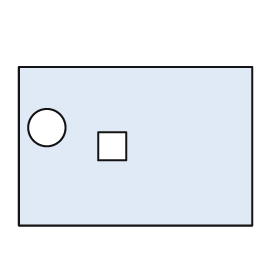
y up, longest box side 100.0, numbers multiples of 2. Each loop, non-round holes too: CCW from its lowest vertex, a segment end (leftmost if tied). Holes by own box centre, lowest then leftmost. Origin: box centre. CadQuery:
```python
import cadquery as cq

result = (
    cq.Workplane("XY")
    .moveTo(-50.0, -34.0)
    .lineTo(50.0, -34.0)
    .lineTo(50.0, 34.0)
    .lineTo(-50.0, 34.0)
    .close()
    .moveTo(-16.0, -6.0)
    .lineTo(-4.0, -6.0)
    .lineTo(-4.0, 6.0)
    .lineTo(-16.0, 6.0)
    .close()
    .moveTo(-38.0, 8.0)
    .circle(8.0)
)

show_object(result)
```